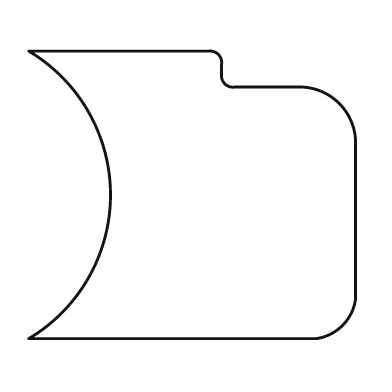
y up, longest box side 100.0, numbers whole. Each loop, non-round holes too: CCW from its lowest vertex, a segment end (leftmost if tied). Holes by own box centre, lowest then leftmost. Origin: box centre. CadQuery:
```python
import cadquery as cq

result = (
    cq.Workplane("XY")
    .moveTo(-50.0, -44.0)
    .lineTo(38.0, -44.0)
    .threePointArc((46.0, -40.0), (50.0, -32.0))
    .lineTo(50.0, 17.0)
    .threePointArc((45.0, 28.0), (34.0, 33.0))
    .lineTo(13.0, 33.0)
    .threePointArc((10.0, 34.0), (9.0, 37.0))
    .lineTo(9.0, 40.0)
    .threePointArc((8.0, 43.0), (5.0, 44.0))
    .lineTo(-50.0, 44.0)
    .threePointArc((-25.0, 0.0), (-50.0, -44.0))
    .close()
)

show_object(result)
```